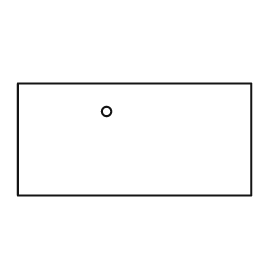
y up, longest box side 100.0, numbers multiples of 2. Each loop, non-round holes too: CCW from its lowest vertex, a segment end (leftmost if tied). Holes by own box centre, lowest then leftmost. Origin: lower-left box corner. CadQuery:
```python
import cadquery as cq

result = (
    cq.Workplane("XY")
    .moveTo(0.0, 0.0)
    .lineTo(100.0, 0.0)
    .lineTo(100.0, 48.0)
    .lineTo(0.0, 48.0)
    .close()
    .moveTo(38.0, 36.0)
    .circle(2.0)
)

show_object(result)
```